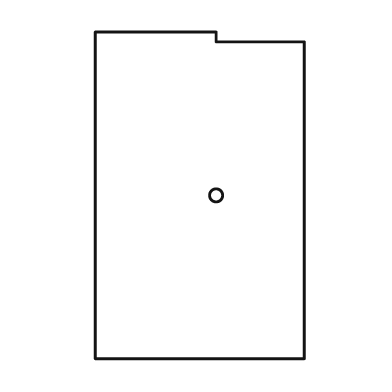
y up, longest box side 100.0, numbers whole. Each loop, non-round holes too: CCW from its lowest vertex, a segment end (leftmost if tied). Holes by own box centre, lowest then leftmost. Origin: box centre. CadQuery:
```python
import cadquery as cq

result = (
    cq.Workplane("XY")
    .moveTo(-32.0, -50.0)
    .lineTo(32.0, -50.0)
    .lineTo(32.0, 47.0)
    .lineTo(5.0, 47.0)
    .lineTo(5.0, 50.0)
    .lineTo(-32.0, 50.0)
    .close()
    .moveTo(5.0, 0.0)
    .circle(2.0)
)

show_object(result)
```